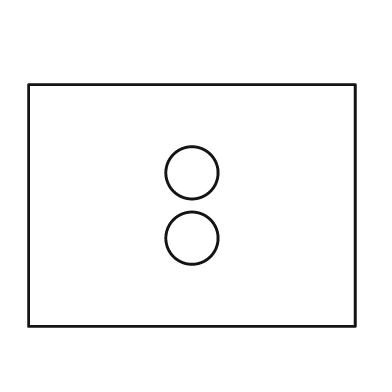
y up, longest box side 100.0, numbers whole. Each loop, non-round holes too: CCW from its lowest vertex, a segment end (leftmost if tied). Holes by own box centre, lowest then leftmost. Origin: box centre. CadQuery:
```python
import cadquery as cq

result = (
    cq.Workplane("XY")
    .moveTo(-50.0, -37.0)
    .lineTo(50.0, -37.0)
    .lineTo(50.0, 37.0)
    .lineTo(-50.0, 37.0)
    .close()
    .moveTo(0.0, -10.0)
    .circle(8.0)
    .moveTo(0.0, 10.0)
    .circle(8.0)
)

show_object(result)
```